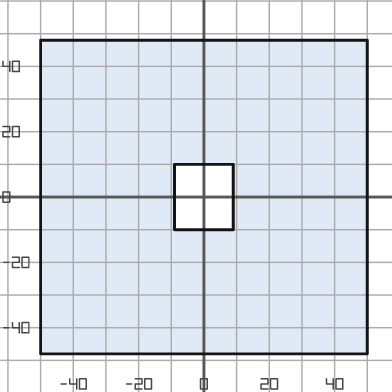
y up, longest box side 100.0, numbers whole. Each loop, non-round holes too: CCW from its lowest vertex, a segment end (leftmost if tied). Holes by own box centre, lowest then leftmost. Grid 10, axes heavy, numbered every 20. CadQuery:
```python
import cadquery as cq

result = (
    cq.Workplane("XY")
    .moveTo(-50.0, -48.0)
    .lineTo(50.0, -48.0)
    .lineTo(50.0, 48.0)
    .lineTo(-50.0, 48.0)
    .close()
    .moveTo(-9.0, -10.0)
    .lineTo(9.0, -10.0)
    .lineTo(9.0, 10.0)
    .lineTo(-9.0, 10.0)
    .close()
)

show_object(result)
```